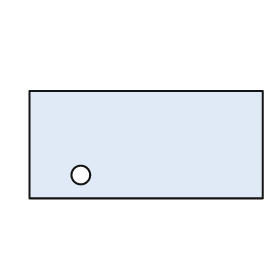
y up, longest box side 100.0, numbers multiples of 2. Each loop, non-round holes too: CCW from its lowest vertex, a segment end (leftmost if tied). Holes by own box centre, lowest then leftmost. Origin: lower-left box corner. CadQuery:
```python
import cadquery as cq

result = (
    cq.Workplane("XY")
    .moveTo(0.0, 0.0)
    .lineTo(100.0, 0.0)
    .lineTo(100.0, 46.0)
    .lineTo(0.0, 46.0)
    .close()
    .moveTo(22.0, 10.0)
    .circle(4.0)
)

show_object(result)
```